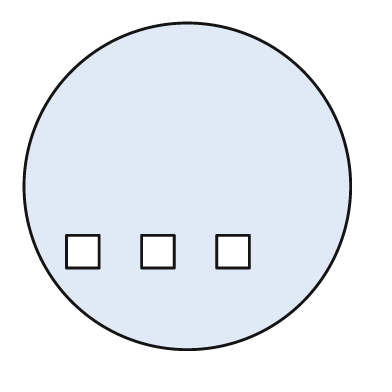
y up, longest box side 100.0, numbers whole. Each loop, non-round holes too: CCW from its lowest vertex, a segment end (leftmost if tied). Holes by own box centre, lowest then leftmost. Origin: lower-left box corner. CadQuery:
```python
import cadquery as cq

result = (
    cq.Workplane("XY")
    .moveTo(50.0, 50.0)
    .circle(50.0)
    .moveTo(13.0, 25.0)
    .lineTo(23.0, 25.0)
    .lineTo(23.0, 35.0)
    .lineTo(13.0, 35.0)
    .close()
    .moveTo(36.0, 25.0)
    .lineTo(46.0, 25.0)
    .lineTo(46.0, 35.0)
    .lineTo(36.0, 35.0)
    .close()
    .moveTo(59.0, 25.0)
    .lineTo(69.0, 25.0)
    .lineTo(69.0, 35.0)
    .lineTo(59.0, 35.0)
    .close()
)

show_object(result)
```